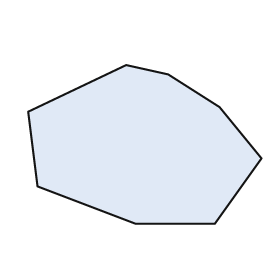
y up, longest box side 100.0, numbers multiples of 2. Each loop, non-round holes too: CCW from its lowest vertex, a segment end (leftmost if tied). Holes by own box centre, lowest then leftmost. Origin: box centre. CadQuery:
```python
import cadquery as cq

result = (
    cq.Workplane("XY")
    .moveTo(-4.0, -34.0)
    .lineTo(30.0, -34.0)
    .lineTo(50.0, -6.0)
    .lineTo(32.0, 16.0)
    .lineTo(10.0, 30.0)
    .lineTo(-8.0, 34.0)
    .lineTo(-50.0, 14.0)
    .lineTo(-46.0, -18.0)
    .close()
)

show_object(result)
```